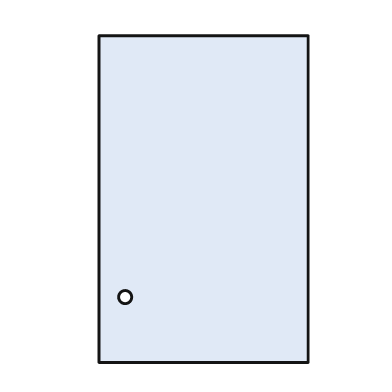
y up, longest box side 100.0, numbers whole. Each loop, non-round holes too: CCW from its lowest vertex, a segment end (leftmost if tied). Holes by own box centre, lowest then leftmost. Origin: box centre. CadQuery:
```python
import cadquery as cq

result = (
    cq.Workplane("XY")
    .moveTo(-32.0, -50.0)
    .lineTo(32.0, -50.0)
    .lineTo(32.0, 50.0)
    .lineTo(-32.0, 50.0)
    .close()
    .moveTo(-24.0, -30.0)
    .circle(2.0)
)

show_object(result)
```